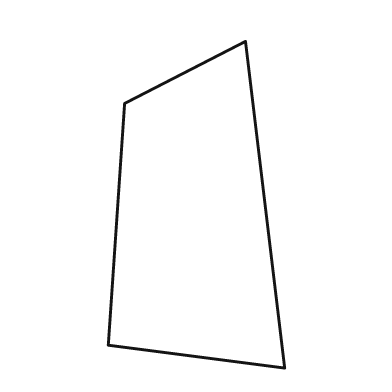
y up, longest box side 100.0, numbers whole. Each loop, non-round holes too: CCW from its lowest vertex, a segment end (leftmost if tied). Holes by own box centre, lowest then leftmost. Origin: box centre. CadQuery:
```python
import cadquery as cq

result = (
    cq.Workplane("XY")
    .moveTo(27.0, -50.0)
    .lineTo(15.0, 50.0)
    .lineTo(-22.0, 31.0)
    .lineTo(-27.0, -43.0)
    .close()
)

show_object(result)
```